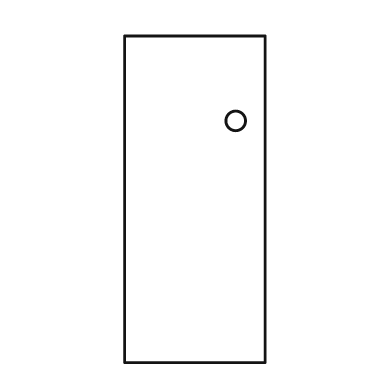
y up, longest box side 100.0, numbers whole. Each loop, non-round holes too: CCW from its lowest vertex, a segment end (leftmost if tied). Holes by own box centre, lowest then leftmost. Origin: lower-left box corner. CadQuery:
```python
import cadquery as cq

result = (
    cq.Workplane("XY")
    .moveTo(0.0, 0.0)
    .lineTo(43.0, 0.0)
    .lineTo(43.0, 100.0)
    .lineTo(0.0, 100.0)
    .close()
    .moveTo(34.0, 74.0)
    .circle(3.0)
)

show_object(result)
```